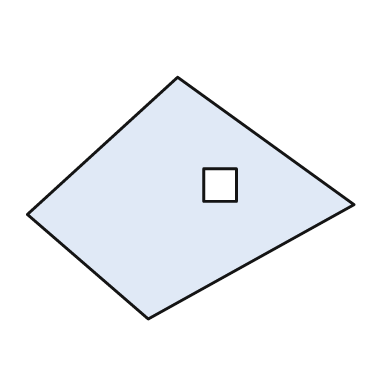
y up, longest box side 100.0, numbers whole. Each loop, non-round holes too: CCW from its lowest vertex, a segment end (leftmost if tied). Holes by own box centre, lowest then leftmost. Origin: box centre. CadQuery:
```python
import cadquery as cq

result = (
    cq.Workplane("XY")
    .moveTo(-13.0, -37.0)
    .lineTo(50.0, -2.0)
    .lineTo(-4.0, 37.0)
    .lineTo(-50.0, -5.0)
    .close()
    .moveTo(4.0, -1.0)
    .lineTo(14.0, -1.0)
    .lineTo(14.0, 9.0)
    .lineTo(4.0, 9.0)
    .close()
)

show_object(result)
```